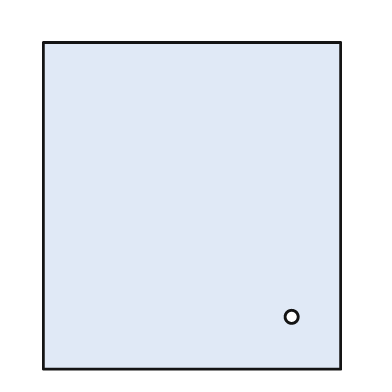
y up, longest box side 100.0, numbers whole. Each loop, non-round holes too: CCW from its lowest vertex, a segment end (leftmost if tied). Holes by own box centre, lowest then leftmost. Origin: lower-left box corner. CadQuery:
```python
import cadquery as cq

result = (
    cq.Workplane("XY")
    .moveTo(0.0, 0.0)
    .lineTo(91.0, 0.0)
    .lineTo(91.0, 100.0)
    .lineTo(0.0, 100.0)
    .close()
    .moveTo(76.0, 16.0)
    .circle(2.0)
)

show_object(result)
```